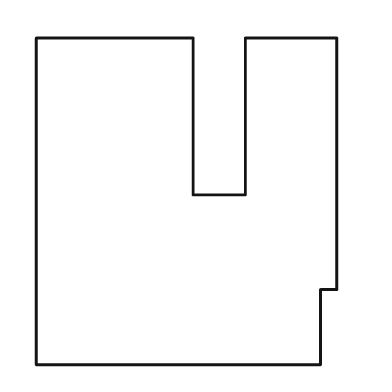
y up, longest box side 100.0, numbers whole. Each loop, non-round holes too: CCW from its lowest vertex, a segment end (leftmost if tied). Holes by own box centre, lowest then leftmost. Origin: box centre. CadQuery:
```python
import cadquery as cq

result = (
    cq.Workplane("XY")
    .moveTo(-46.0, -50.0)
    .lineTo(41.0, -50.0)
    .lineTo(41.0, -27.0)
    .lineTo(46.0, -27.0)
    .lineTo(46.0, 50.0)
    .lineTo(18.0, 50.0)
    .lineTo(18.0, 2.0)
    .lineTo(2.0, 2.0)
    .lineTo(2.0, 50.0)
    .lineTo(-46.0, 50.0)
    .close()
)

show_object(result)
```